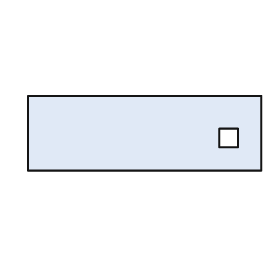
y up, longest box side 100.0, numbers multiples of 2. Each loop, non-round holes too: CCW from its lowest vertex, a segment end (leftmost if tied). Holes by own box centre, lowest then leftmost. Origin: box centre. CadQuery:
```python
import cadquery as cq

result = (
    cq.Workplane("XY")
    .moveTo(-50.0, -16.0)
    .lineTo(50.0, -16.0)
    .lineTo(50.0, 16.0)
    .lineTo(-50.0, 16.0)
    .close()
    .moveTo(32.0, -6.0)
    .lineTo(40.0, -6.0)
    .lineTo(40.0, 2.0)
    .lineTo(32.0, 2.0)
    .close()
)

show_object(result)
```